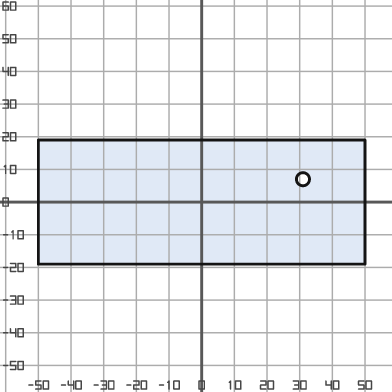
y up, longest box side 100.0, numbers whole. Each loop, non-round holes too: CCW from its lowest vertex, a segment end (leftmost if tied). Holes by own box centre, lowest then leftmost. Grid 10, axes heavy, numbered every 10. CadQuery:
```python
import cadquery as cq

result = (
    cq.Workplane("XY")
    .moveTo(-50.0, -19.0)
    .lineTo(50.0, -19.0)
    .lineTo(50.0, 19.0)
    .lineTo(-50.0, 19.0)
    .close()
    .moveTo(31.0, 7.0)
    .circle(2.0)
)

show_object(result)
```